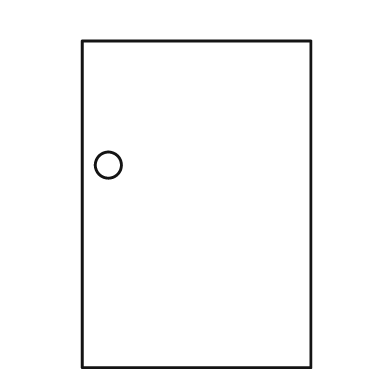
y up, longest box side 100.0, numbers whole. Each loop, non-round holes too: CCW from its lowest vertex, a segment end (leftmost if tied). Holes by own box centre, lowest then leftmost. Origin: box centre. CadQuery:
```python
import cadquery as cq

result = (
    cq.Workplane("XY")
    .moveTo(-35.0, -50.0)
    .lineTo(35.0, -50.0)
    .lineTo(35.0, 50.0)
    .lineTo(-35.0, 50.0)
    .close()
    .moveTo(-27.0, 12.0)
    .circle(4.0)
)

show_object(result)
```